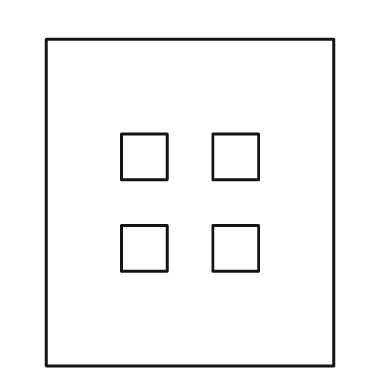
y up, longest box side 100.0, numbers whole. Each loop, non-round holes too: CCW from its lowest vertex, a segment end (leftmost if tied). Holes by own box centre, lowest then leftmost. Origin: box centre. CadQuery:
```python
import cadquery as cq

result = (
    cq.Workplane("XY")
    .moveTo(-44.0, -50.0)
    .lineTo(44.0, -50.0)
    .lineTo(44.0, 50.0)
    .lineTo(-44.0, 50.0)
    .close()
    .moveTo(-21.0, -21.0)
    .lineTo(-7.0, -21.0)
    .lineTo(-7.0, -7.0)
    .lineTo(-21.0, -7.0)
    .close()
    .moveTo(7.0, -21.0)
    .lineTo(21.0, -21.0)
    .lineTo(21.0, -7.0)
    .lineTo(7.0, -7.0)
    .close()
    .moveTo(-21.0, 7.0)
    .lineTo(-7.0, 7.0)
    .lineTo(-7.0, 21.0)
    .lineTo(-21.0, 21.0)
    .close()
    .moveTo(7.0, 7.0)
    .lineTo(21.0, 7.0)
    .lineTo(21.0, 21.0)
    .lineTo(7.0, 21.0)
    .close()
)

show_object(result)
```